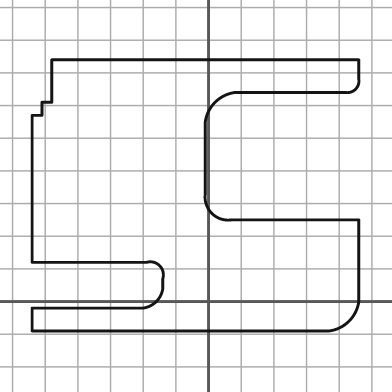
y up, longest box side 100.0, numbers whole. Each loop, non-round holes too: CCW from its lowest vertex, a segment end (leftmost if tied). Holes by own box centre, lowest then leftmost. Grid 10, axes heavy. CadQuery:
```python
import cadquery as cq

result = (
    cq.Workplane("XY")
    .moveTo(-54.0, -9.0)
    .lineTo(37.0, -9.0)
    .threePointArc((43.0, -6.0), (46.0, 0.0))
    .lineTo(46.0, 25.0)
    .lineTo(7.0, 25.0)
    .threePointArc((1.0, 27.0), (-1.0, 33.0))
    .lineTo(-1.0, 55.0)
    .threePointArc((2.0, 61.0), (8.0, 64.0))
    .lineTo(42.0, 64.0)
    .threePointArc((45.0, 65.0), (46.0, 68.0))
    .lineTo(46.0, 74.0)
    .lineTo(-48.0, 74.0)
    .lineTo(-48.0, 61.0)
    .lineTo(-51.0, 61.0)
    .lineTo(-51.0, 57.0)
    .lineTo(-54.0, 57.0)
    .lineTo(-54.0, 12.0)
    .lineTo(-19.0, 12.0)
    .threePointArc((-15.0, 11.0), (-14.0, 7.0))
    .lineTo(-14.0, 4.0)
    .threePointArc((-16.0, 0.0), (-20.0, -2.0))
    .lineTo(-54.0, -2.0)
    .close()
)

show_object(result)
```